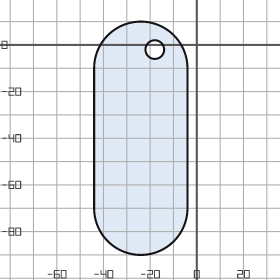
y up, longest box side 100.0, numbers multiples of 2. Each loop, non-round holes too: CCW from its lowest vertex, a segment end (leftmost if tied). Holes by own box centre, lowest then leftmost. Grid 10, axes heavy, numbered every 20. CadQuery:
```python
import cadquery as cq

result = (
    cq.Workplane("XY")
    .moveTo(-44.0, -70.0)
    .threePointArc((-24.0, -90.0), (-4.0, -70.0))
    .lineTo(-4.0, -10.0)
    .threePointArc((-24.0, 10.0), (-44.0, -10.0))
    .close()
    .moveTo(-18.0, -2.0)
    .circle(4.0)
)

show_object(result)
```